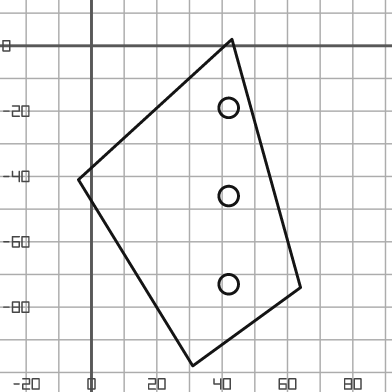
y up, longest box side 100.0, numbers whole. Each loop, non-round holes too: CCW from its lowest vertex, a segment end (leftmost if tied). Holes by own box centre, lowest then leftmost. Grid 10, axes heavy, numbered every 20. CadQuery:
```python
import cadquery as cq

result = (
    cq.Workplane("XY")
    .moveTo(31.0, -98.0)
    .lineTo(64.0, -74.0)
    .lineTo(43.0, 2.0)
    .lineTo(-4.0, -41.0)
    .close()
    .moveTo(42.0, -73.0)
    .circle(3.0)
    .moveTo(42.0, -46.0)
    .circle(3.0)
    .moveTo(42.0, -19.0)
    .circle(3.0)
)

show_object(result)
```